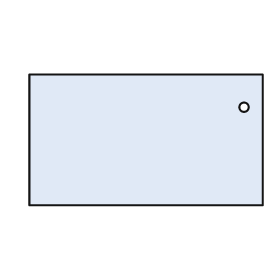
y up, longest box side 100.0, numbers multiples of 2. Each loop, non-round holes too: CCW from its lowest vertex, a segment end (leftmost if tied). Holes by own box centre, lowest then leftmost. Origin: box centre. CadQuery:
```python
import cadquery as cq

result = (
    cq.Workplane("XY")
    .moveTo(-50.0, -28.0)
    .lineTo(50.0, -28.0)
    .lineTo(50.0, 28.0)
    .lineTo(-50.0, 28.0)
    .close()
    .moveTo(42.0, 14.0)
    .circle(2.0)
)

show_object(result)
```